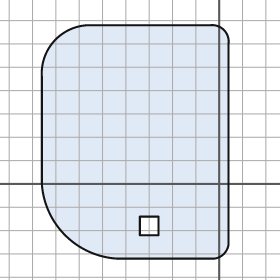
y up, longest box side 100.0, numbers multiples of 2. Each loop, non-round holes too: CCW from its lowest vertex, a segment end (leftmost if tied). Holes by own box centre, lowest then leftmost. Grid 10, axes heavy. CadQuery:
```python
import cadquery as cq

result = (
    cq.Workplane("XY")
    .moveTo(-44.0, -32.0)
    .lineTo(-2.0, -32.0)
    .threePointArc((2.0, -30.0), (4.0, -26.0))
    .lineTo(4.0, 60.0)
    .threePointArc((2.0, 66.0), (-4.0, 68.0))
    .lineTo(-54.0, 68.0)
    .threePointArc((-70.0, 62.0), (-76.0, 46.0))
    .lineTo(-76.0, 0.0)
    .threePointArc((-66.0, -22.0), (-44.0, -32.0))
    .close()
    .moveTo(-34.0, -22.0)
    .lineTo(-26.0, -22.0)
    .lineTo(-26.0, -14.0)
    .lineTo(-34.0, -14.0)
    .close()
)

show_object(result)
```